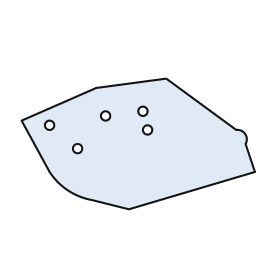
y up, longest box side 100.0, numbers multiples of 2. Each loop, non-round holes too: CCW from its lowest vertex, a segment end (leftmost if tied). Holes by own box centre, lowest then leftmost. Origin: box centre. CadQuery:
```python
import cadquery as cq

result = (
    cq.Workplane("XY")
    .moveTo(-4.0, -28.0)
    .lineTo(50.0, -12.0)
    .lineTo(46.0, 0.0)
    .threePointArc((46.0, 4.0), (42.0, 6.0))
    .lineTo(12.0, 28.0)
    .lineTo(-18.0, 24.0)
    .lineTo(-50.0, 10.0)
    .lineTo(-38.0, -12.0)
    .threePointArc((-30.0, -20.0), (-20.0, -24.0))
    .close()
    .moveTo(-26.0, -2.0)
    .circle(2.0)
    .moveTo(4.0, 6.0)
    .circle(2.0)
    .moveTo(-38.0, 8.0)
    .circle(2.0)
    .moveTo(-14.0, 12.0)
    .circle(2.0)
    .moveTo(2.0, 14.0)
    .circle(2.0)
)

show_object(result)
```